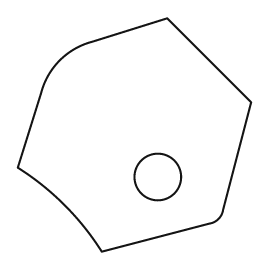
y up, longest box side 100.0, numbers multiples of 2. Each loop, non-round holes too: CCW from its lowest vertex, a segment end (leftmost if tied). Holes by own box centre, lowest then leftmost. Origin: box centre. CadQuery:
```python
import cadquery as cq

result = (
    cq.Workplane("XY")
    .moveTo(-14.0, -50.0)
    .lineTo(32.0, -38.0)
    .threePointArc((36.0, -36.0), (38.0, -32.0))
    .lineTo(50.0, 14.0)
    .lineTo(14.0, 50.0)
    .lineTo(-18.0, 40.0)
    .threePointArc((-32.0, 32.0), (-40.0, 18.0))
    .lineTo(-50.0, -14.0)
    .threePointArc((-30.0, -30.0), (-14.0, -50.0))
    .close()
    .moveTo(10.0, -18.0)
    .circle(10.0)
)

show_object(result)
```